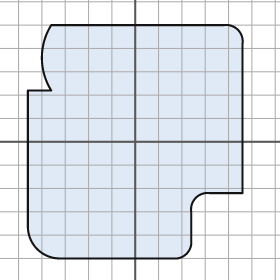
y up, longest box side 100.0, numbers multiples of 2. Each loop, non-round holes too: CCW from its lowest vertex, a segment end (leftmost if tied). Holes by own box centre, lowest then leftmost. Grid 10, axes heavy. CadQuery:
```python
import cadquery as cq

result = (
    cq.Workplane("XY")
    .moveTo(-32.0, -50.0)
    .lineTo(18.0, -50.0)
    .threePointArc((22.0, -48.0), (24.0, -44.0))
    .lineTo(24.0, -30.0)
    .threePointArc((26.0, -24.0), (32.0, -22.0))
    .lineTo(46.0, -22.0)
    .lineTo(46.0, 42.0)
    .threePointArc((44.0, 48.0), (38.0, 50.0))
    .lineTo(-36.0, 50.0)
    .threePointArc((-40.0, 36.0), (-36.0, 22.0))
    .lineTo(-46.0, 22.0)
    .lineTo(-46.0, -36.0)
    .threePointArc((-42.0, -46.0), (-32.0, -50.0))
    .close()
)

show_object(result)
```